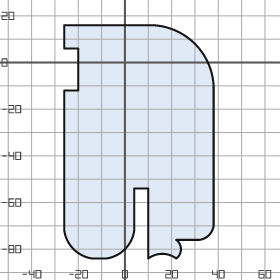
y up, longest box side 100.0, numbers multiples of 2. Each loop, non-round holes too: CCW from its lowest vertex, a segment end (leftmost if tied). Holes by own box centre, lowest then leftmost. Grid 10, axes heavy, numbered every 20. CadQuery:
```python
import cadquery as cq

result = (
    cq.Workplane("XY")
    .moveTo(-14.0, -84.0)
    .lineTo(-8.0, -84.0)
    .threePointArc((0.0, -80.0), (4.0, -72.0))
    .lineTo(4.0, -54.0)
    .lineTo(10.0, -54.0)
    .lineTo(10.0, -84.0)
    .threePointArc((16.0, -82.0), (22.0, -84.0))
    .threePointArc((24.0, -80.0), (22.0, -76.0))
    .lineTo(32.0, -76.0)
    .threePointArc((36.0, -74.0), (38.0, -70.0))
    .lineTo(38.0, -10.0)
    .threePointArc((30.0, 8.0), (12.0, 16.0))
    .lineTo(-26.0, 16.0)
    .lineTo(-26.0, 6.0)
    .lineTo(-20.0, 6.0)
    .lineTo(-20.0, -12.0)
    .lineTo(-26.0, -12.0)
    .lineTo(-26.0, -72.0)
    .threePointArc((-22.0, -80.0), (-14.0, -84.0))
    .close()
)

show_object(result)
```